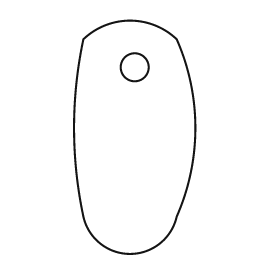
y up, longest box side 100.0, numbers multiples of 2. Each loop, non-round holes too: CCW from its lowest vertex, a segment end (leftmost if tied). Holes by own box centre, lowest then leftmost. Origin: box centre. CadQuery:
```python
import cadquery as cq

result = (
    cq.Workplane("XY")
    .moveTo(-22.0, -34.0)
    .threePointArc((-2.0, -50.0), (18.0, -34.0))
    .threePointArc((26.0, 4.0), (18.0, 42.0))
    .threePointArc((-2.0, 50.0), (-22.0, 42.0))
    .threePointArc((-26.0, 4.0), (-22.0, -34.0))
    .close()
    .moveTo(0.0, 30.0)
    .circle(6.0)
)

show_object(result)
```